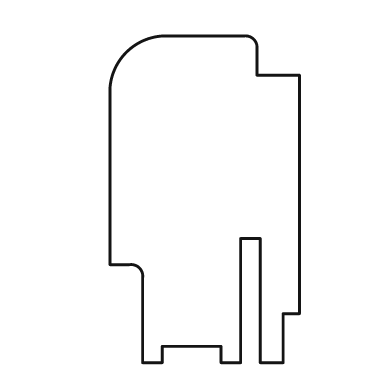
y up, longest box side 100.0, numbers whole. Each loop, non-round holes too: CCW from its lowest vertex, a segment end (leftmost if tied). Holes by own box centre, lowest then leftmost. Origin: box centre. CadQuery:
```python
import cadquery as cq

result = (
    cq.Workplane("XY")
    .moveTo(-19.0, -50.0)
    .lineTo(-13.0, -50.0)
    .lineTo(-13.0, -45.0)
    .lineTo(5.0, -45.0)
    .lineTo(5.0, -50.0)
    .lineTo(11.0, -50.0)
    .lineTo(11.0, -12.0)
    .lineTo(17.0, -12.0)
    .lineTo(17.0, -50.0)
    .lineTo(24.0, -50.0)
    .lineTo(24.0, -35.0)
    .lineTo(29.0, -35.0)
    .lineTo(29.0, 38.0)
    .lineTo(16.0, 38.0)
    .lineTo(16.0, 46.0)
    .threePointArc((15.0, 49.0), (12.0, 50.0))
    .lineTo(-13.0, 50.0)
    .threePointArc((-24.0, 45.0), (-29.0, 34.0))
    .lineTo(-29.0, -20.0)
    .lineTo(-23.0, -20.0)
    .threePointArc((-20.0, -21.0), (-19.0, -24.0))
    .close()
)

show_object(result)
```